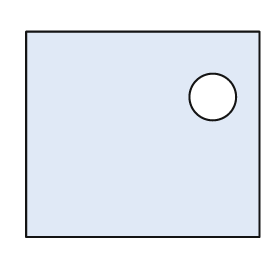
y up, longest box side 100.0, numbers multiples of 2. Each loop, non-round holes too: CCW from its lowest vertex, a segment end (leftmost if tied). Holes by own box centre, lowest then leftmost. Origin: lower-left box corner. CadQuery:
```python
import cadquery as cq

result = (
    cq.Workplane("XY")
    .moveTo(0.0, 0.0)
    .lineTo(100.0, 0.0)
    .lineTo(100.0, 88.0)
    .lineTo(0.0, 88.0)
    .close()
    .moveTo(80.0, 60.0)
    .circle(10.0)
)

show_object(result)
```